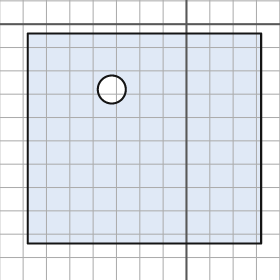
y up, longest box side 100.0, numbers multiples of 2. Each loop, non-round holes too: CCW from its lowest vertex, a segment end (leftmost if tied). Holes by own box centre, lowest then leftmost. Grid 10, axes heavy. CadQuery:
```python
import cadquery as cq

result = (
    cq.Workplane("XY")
    .moveTo(-68.0, -94.0)
    .lineTo(32.0, -94.0)
    .lineTo(32.0, -4.0)
    .lineTo(-68.0, -4.0)
    .close()
    .moveTo(-32.0, -28.0)
    .circle(6.0)
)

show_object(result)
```